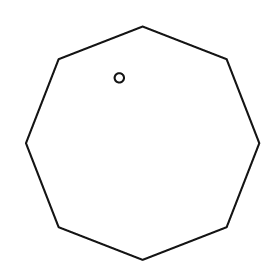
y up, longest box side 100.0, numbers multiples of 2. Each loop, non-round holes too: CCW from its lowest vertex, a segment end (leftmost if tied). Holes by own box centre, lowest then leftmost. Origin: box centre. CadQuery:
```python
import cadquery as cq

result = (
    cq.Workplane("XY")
    .moveTo(0.0, -50.0)
    .lineTo(36.0, -36.0)
    .lineTo(50.0, 0.0)
    .lineTo(36.0, 36.0)
    .lineTo(0.0, 50.0)
    .lineTo(-36.0, 36.0)
    .lineTo(-50.0, 0.0)
    .lineTo(-36.0, -36.0)
    .close()
    .moveTo(-10.0, 28.0)
    .circle(2.0)
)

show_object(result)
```